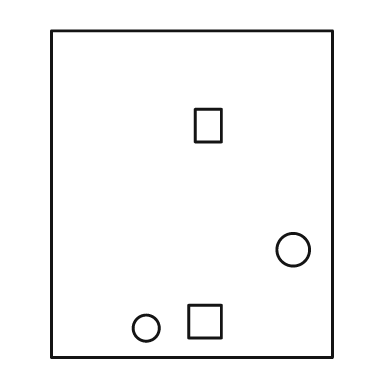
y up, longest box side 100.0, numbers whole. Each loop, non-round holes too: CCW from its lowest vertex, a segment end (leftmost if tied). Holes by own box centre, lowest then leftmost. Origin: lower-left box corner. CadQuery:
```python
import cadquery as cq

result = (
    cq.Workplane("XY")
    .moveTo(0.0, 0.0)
    .lineTo(86.0, 0.0)
    .lineTo(86.0, 100.0)
    .lineTo(0.0, 100.0)
    .close()
    .moveTo(29.0, 9.0)
    .circle(4.0)
    .moveTo(42.0, 6.0)
    .lineTo(52.0, 6.0)
    .lineTo(52.0, 16.0)
    .lineTo(42.0, 16.0)
    .close()
    .moveTo(74.0, 33.0)
    .circle(5.0)
    .moveTo(44.0, 66.0)
    .lineTo(52.0, 66.0)
    .lineTo(52.0, 76.0)
    .lineTo(44.0, 76.0)
    .close()
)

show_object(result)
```